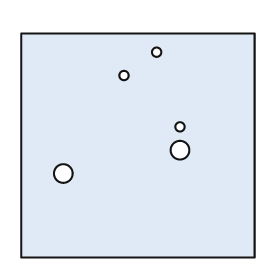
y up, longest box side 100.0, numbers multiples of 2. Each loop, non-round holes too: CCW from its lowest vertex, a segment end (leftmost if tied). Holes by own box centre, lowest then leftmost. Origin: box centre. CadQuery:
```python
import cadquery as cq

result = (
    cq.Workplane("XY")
    .moveTo(-50.0, -48.0)
    .lineTo(50.0, -48.0)
    .lineTo(50.0, 48.0)
    .lineTo(-50.0, 48.0)
    .close()
    .moveTo(-32.0, -12.0)
    .circle(4.0)
    .moveTo(18.0, -2.0)
    .circle(4.0)
    .moveTo(18.0, 8.0)
    .circle(2.0)
    .moveTo(-6.0, 30.0)
    .circle(2.0)
    .moveTo(8.0, 40.0)
    .circle(2.0)
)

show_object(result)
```